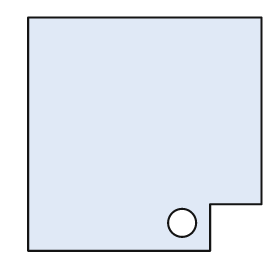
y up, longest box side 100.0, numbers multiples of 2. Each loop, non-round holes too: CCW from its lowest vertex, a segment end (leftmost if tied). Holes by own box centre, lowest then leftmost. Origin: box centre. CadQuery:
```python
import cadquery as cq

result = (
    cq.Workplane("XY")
    .moveTo(-50.0, -50.0)
    .lineTo(28.0, -50.0)
    .lineTo(28.0, -30.0)
    .lineTo(50.0, -30.0)
    .lineTo(50.0, 50.0)
    .lineTo(-50.0, 50.0)
    .close()
    .moveTo(16.0, -38.0)
    .circle(6.0)
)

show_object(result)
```